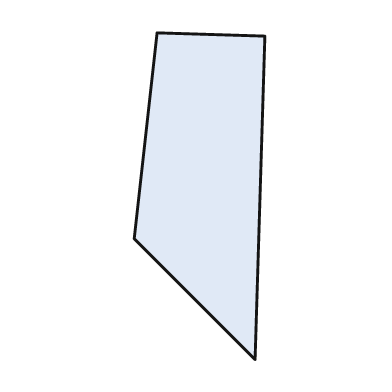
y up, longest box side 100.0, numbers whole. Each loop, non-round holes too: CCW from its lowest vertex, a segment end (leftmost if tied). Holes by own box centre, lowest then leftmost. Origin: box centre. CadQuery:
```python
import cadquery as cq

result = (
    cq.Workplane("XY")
    .moveTo(17.0, -50.0)
    .lineTo(20.0, 49.0)
    .lineTo(-13.0, 50.0)
    .lineTo(-20.0, -13.0)
    .close()
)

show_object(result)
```